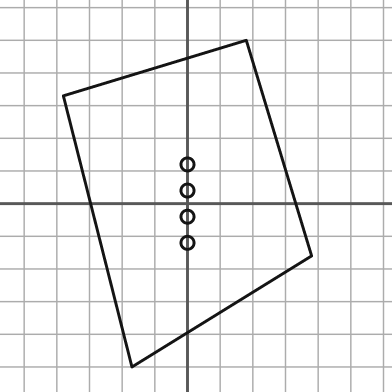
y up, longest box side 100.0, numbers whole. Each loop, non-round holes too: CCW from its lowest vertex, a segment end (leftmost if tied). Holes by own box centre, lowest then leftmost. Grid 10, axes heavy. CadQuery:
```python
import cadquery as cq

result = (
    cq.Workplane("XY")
    .moveTo(-17.0, -50.0)
    .lineTo(38.0, -16.0)
    .lineTo(18.0, 50.0)
    .lineTo(-38.0, 33.0)
    .close()
    .moveTo(0.0, -12.0)
    .circle(2.0)
    .moveTo(0.0, -4.0)
    .circle(2.0)
    .moveTo(0.0, 4.0)
    .circle(2.0)
    .moveTo(0.0, 12.0)
    .circle(2.0)
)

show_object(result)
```